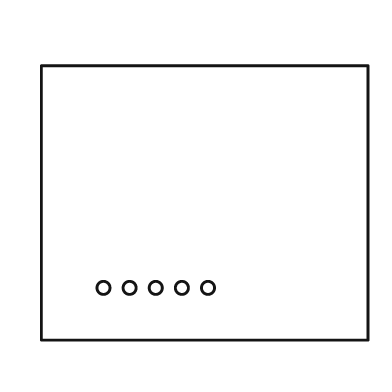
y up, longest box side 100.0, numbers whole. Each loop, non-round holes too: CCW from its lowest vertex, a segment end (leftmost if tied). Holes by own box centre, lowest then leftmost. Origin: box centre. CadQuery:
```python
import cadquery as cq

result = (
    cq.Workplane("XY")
    .moveTo(-50.0, -42.0)
    .lineTo(50.0, -42.0)
    .lineTo(50.0, 42.0)
    .lineTo(-50.0, 42.0)
    .close()
    .moveTo(-31.0, -26.0)
    .circle(2.0)
    .moveTo(-23.0, -26.0)
    .circle(2.0)
    .moveTo(-15.0, -26.0)
    .circle(2.0)
    .moveTo(-7.0, -26.0)
    .circle(2.0)
    .moveTo(1.0, -26.0)
    .circle(2.0)
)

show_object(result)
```